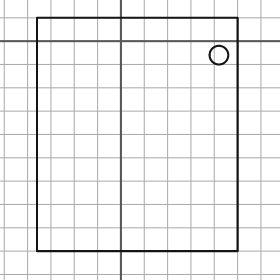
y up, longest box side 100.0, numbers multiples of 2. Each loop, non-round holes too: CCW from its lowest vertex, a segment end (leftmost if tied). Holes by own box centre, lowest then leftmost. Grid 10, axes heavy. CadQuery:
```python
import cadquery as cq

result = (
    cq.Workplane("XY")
    .moveTo(-36.0, -90.0)
    .lineTo(50.0, -90.0)
    .lineTo(50.0, 10.0)
    .lineTo(-36.0, 10.0)
    .close()
    .moveTo(42.0, -6.0)
    .circle(4.0)
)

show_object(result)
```